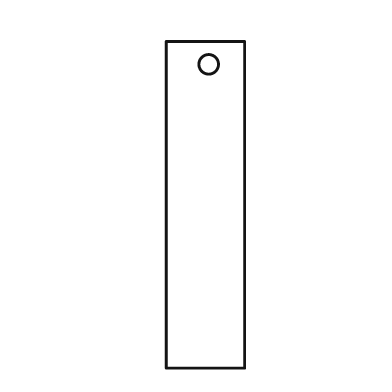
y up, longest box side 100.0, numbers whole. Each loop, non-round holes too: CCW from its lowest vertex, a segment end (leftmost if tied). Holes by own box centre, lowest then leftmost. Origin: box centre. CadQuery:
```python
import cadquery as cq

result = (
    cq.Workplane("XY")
    .moveTo(-12.0, -50.0)
    .lineTo(12.0, -50.0)
    .lineTo(12.0, 50.0)
    .lineTo(-12.0, 50.0)
    .close()
    .moveTo(1.0, 43.0)
    .circle(3.0)
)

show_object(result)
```